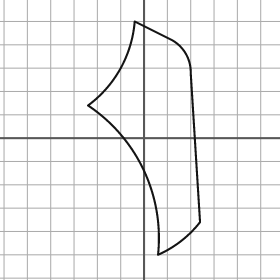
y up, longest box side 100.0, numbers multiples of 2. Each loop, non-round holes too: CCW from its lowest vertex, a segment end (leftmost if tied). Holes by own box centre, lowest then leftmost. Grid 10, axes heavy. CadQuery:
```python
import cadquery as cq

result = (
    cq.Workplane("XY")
    .moveTo(6.0, -50.0)
    .threePointArc((16.0, -44.0), (24.0, -36.0))
    .lineTo(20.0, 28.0)
    .threePointArc((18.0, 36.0), (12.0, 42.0))
    .lineTo(-4.0, 50.0)
    .threePointArc((-10.0, 30.0), (-24.0, 14.0))
    .threePointArc((0.0, -14.0), (6.0, -50.0))
    .close()
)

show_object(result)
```